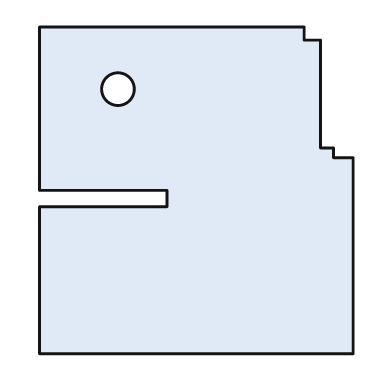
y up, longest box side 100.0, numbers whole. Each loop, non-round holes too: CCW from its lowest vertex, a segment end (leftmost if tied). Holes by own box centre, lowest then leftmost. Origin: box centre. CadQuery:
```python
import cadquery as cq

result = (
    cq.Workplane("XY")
    .moveTo(-48.0, -50.0)
    .lineTo(48.0, -50.0)
    .lineTo(48.0, 10.0)
    .lineTo(42.0, 10.0)
    .lineTo(42.0, 13.0)
    .lineTo(38.0, 13.0)
    .lineTo(38.0, 46.0)
    .lineTo(33.0, 46.0)
    .lineTo(33.0, 50.0)
    .lineTo(-48.0, 50.0)
    .lineTo(-48.0, 0.0)
    .lineTo(-9.0, 0.0)
    .lineTo(-9.0, -5.0)
    .lineTo(-48.0, -5.0)
    .close()
    .moveTo(-24.0, 31.0)
    .circle(5.0)
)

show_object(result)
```